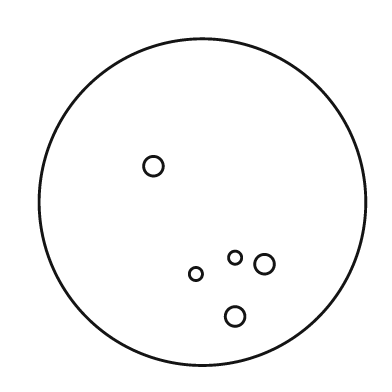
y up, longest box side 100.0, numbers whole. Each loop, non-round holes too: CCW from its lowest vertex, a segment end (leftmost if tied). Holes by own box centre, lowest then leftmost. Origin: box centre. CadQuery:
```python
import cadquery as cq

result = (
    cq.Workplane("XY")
    .moveTo(0.0, 0.0)
    .circle(50.0)
    .moveTo(10.0, -35.0)
    .circle(3.0)
    .moveTo(-2.0, -22.0)
    .circle(2.0)
    .moveTo(19.0, -19.0)
    .circle(3.0)
    .moveTo(10.0, -17.0)
    .circle(2.0)
    .moveTo(-15.0, 11.0)
    .circle(3.0)
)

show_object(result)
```